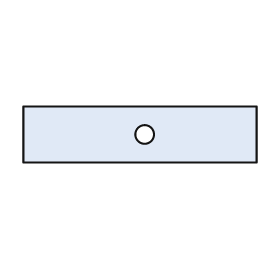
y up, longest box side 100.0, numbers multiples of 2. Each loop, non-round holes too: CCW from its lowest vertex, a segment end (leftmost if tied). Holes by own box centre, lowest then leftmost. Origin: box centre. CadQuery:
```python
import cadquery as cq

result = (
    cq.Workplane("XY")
    .moveTo(-50.0, -12.0)
    .lineTo(50.0, -12.0)
    .lineTo(50.0, 12.0)
    .lineTo(-50.0, 12.0)
    .close()
    .moveTo(2.0, 0.0)
    .circle(4.0)
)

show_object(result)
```